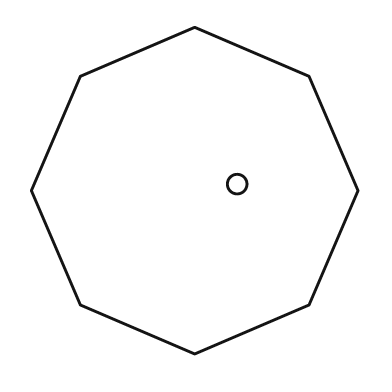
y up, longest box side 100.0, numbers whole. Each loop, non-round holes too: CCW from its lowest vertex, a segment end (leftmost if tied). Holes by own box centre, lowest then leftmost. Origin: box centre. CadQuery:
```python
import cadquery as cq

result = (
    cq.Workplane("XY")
    .moveTo(0.0, -50.0)
    .lineTo(35.0, -35.0)
    .lineTo(50.0, 0.0)
    .lineTo(35.0, 35.0)
    .lineTo(0.0, 50.0)
    .lineTo(-35.0, 35.0)
    .lineTo(-50.0, 0.0)
    .lineTo(-35.0, -35.0)
    .close()
    .moveTo(13.0, 2.0)
    .circle(3.0)
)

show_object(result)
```